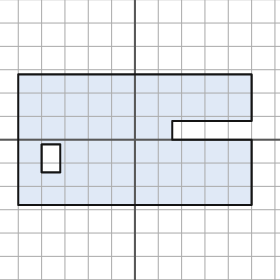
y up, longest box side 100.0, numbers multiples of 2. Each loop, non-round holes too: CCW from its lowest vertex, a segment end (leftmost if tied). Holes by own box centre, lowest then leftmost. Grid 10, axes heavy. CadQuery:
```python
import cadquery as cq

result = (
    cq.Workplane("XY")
    .moveTo(-50.0, -28.0)
    .lineTo(50.0, -28.0)
    .lineTo(50.0, 0.0)
    .lineTo(16.0, 0.0)
    .lineTo(16.0, 8.0)
    .lineTo(50.0, 8.0)
    .lineTo(50.0, 28.0)
    .lineTo(-50.0, 28.0)
    .close()
    .moveTo(-40.0, -14.0)
    .lineTo(-32.0, -14.0)
    .lineTo(-32.0, -2.0)
    .lineTo(-40.0, -2.0)
    .close()
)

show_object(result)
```